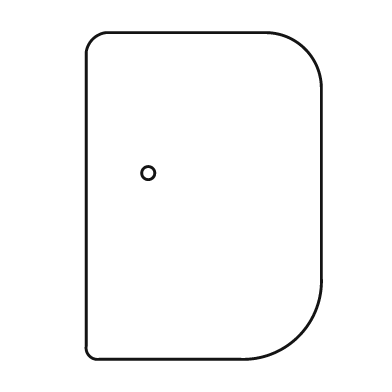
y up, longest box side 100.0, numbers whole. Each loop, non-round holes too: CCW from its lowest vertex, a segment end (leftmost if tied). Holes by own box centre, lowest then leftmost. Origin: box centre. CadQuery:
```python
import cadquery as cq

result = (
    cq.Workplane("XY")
    .moveTo(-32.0, -50.0)
    .lineTo(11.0, -50.0)
    .threePointArc((29.0, -43.0), (36.0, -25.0))
    .lineTo(36.0, 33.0)
    .threePointArc((31.0, 45.0), (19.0, 50.0))
    .lineTo(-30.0, 50.0)
    .threePointArc((-34.0, 48.0), (-36.0, 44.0))
    .lineTo(-36.0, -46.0)
    .threePointArc((-35.0, -49.0), (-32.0, -50.0))
    .close()
    .moveTo(-17.0, 7.0)
    .circle(2.0)
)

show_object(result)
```